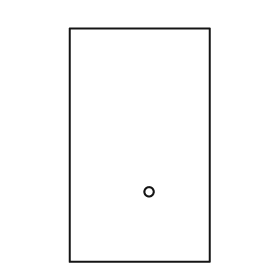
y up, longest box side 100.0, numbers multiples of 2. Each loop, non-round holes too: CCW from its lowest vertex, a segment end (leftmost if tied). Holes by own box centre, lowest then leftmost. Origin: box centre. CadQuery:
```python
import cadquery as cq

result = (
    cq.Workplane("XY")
    .moveTo(-30.0, -50.0)
    .lineTo(30.0, -50.0)
    .lineTo(30.0, 50.0)
    .lineTo(-30.0, 50.0)
    .close()
    .moveTo(4.0, -20.0)
    .circle(2.0)
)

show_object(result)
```